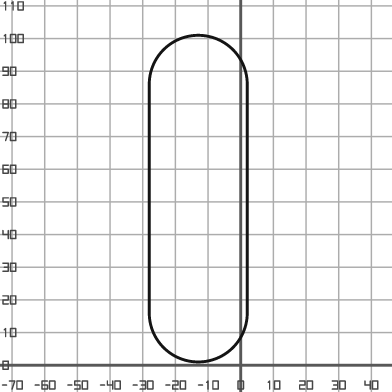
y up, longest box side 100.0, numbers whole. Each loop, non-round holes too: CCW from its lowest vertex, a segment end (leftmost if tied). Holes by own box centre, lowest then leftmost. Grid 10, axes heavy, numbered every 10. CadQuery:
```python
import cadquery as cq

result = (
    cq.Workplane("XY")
    .moveTo(-28.0, 16.0)
    .threePointArc((-13.0, 1.0), (2.0, 16.0))
    .lineTo(2.0, 86.0)
    .threePointArc((-13.0, 101.0), (-28.0, 86.0))
    .close()
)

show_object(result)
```